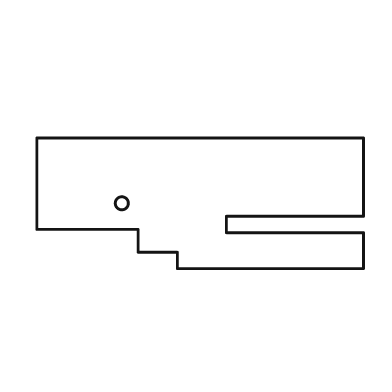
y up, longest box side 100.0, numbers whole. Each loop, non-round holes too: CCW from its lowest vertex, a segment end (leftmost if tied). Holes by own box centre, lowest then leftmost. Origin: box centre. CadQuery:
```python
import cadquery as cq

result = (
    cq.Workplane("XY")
    .moveTo(-7.0, -20.0)
    .lineTo(50.0, -20.0)
    .lineTo(50.0, -9.0)
    .lineTo(8.0, -9.0)
    .lineTo(8.0, -4.0)
    .lineTo(50.0, -4.0)
    .lineTo(50.0, 20.0)
    .lineTo(-50.0, 20.0)
    .lineTo(-50.0, -8.0)
    .lineTo(-19.0, -8.0)
    .lineTo(-19.0, -15.0)
    .lineTo(-7.0, -15.0)
    .close()
    .moveTo(-24.0, 0.0)
    .circle(2.0)
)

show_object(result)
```